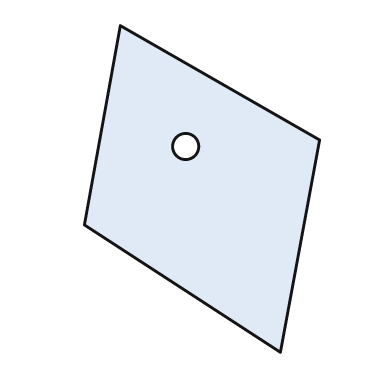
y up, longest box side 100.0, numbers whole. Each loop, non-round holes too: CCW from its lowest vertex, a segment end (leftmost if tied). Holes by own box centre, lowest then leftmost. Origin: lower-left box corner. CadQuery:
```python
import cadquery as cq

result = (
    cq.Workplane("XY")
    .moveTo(60.0, 0.0)
    .lineTo(72.0, 65.0)
    .lineTo(11.0, 100.0)
    .lineTo(0.0, 39.0)
    .close()
    .moveTo(31.0, 63.0)
    .circle(4.0)
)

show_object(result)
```